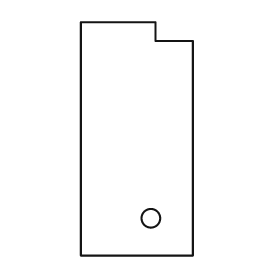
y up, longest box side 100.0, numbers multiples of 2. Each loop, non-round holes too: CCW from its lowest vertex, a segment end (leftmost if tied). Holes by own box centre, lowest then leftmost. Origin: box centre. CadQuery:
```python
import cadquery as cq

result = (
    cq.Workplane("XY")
    .moveTo(-24.0, -50.0)
    .lineTo(24.0, -50.0)
    .lineTo(24.0, 42.0)
    .lineTo(8.0, 42.0)
    .lineTo(8.0, 50.0)
    .lineTo(-24.0, 50.0)
    .close()
    .moveTo(6.0, -34.0)
    .circle(4.0)
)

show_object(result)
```